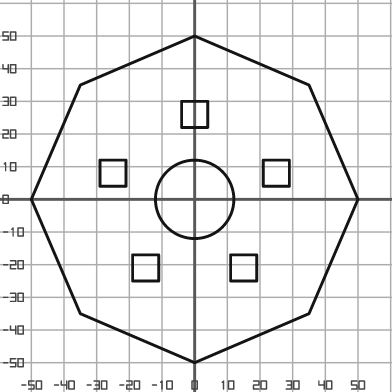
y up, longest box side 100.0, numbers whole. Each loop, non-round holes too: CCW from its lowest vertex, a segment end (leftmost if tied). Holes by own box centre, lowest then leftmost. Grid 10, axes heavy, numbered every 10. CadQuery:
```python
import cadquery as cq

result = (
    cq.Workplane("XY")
    .moveTo(0.0, -50.0)
    .lineTo(35.0, -35.0)
    .lineTo(50.0, 0.0)
    .lineTo(35.0, 35.0)
    .lineTo(0.0, 50.0)
    .lineTo(-35.0, 35.0)
    .lineTo(-50.0, 0.0)
    .lineTo(-35.0, -35.0)
    .close()
    .moveTo(-19.0, -25.0)
    .lineTo(-11.0, -25.0)
    .lineTo(-11.0, -17.0)
    .lineTo(-19.0, -17.0)
    .close()
    .moveTo(11.0, -25.0)
    .lineTo(19.0, -25.0)
    .lineTo(19.0, -17.0)
    .lineTo(11.0, -17.0)
    .close()
    .moveTo(0.0, 0.0)
    .circle(12.0)
    .moveTo(-29.0, 4.0)
    .lineTo(-21.0, 4.0)
    .lineTo(-21.0, 12.0)
    .lineTo(-29.0, 12.0)
    .close()
    .moveTo(21.0, 4.0)
    .lineTo(29.0, 4.0)
    .lineTo(29.0, 12.0)
    .lineTo(21.0, 12.0)
    .close()
    .moveTo(-4.0, 22.0)
    .lineTo(4.0, 22.0)
    .lineTo(4.0, 30.0)
    .lineTo(-4.0, 30.0)
    .close()
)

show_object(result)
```